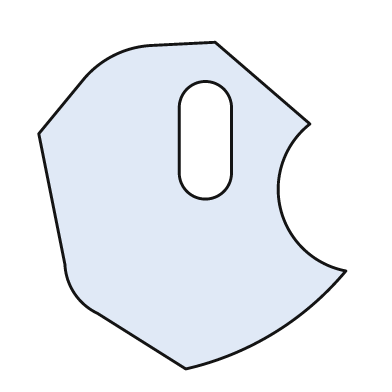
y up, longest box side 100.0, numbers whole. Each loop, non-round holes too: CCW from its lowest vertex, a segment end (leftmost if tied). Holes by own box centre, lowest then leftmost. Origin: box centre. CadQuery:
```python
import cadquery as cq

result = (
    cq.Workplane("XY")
    .moveTo(-2.0, -50.0)
    .threePointArc((25.0, -39.0), (47.0, -20.0))
    .threePointArc((27.0, -1.0), (36.0, 25.0))
    .lineTo(7.0, 50.0)
    .lineTo(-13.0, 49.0)
    .threePointArc((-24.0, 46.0), (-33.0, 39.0))
    .lineTo(-47.0, 22.0)
    .lineTo(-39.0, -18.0)
    .threePointArc((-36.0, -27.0), (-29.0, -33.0))
    .close()
    .moveTo(-4.0, 10.0)
    .threePointArc((4.0, 2.0), (12.0, 10.0))
    .lineTo(12.0, 30.0)
    .threePointArc((4.0, 38.0), (-4.0, 30.0))
    .close()
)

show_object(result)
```